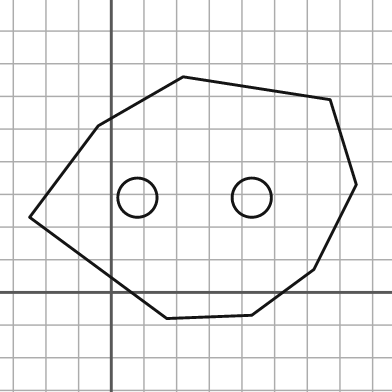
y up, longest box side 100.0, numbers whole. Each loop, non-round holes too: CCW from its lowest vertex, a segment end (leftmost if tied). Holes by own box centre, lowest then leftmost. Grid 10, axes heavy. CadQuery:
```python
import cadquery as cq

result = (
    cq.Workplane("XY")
    .moveTo(17.0, -8.0)
    .lineTo(43.0, -7.0)
    .lineTo(62.0, 7.0)
    .lineTo(75.0, 33.0)
    .lineTo(67.0, 59.0)
    .lineTo(22.0, 66.0)
    .lineTo(-4.0, 51.0)
    .lineTo(-25.0, 23.0)
    .close()
    .moveTo(8.0, 29.0)
    .circle(6.0)
    .moveTo(43.0, 29.0)
    .circle(6.0)
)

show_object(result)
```